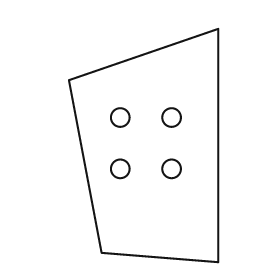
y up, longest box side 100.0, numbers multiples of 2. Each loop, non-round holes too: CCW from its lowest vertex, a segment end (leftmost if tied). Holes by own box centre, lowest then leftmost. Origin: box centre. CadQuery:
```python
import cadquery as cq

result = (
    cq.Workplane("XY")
    .moveTo(32.0, -50.0)
    .lineTo(32.0, 50.0)
    .lineTo(-32.0, 28.0)
    .lineTo(-18.0, -46.0)
    .close()
    .moveTo(-10.0, -10.0)
    .circle(4.0)
    .moveTo(12.0, -10.0)
    .circle(4.0)
    .moveTo(-10.0, 12.0)
    .circle(4.0)
    .moveTo(12.0, 12.0)
    .circle(4.0)
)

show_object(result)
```